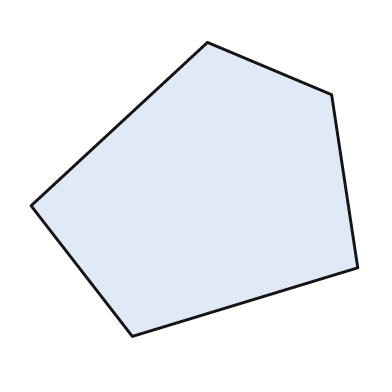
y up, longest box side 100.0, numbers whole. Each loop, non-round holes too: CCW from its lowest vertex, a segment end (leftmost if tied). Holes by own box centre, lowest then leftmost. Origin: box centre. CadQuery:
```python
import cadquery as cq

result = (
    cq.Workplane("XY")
    .moveTo(-19.0, -45.0)
    .lineTo(50.0, -24.0)
    .lineTo(42.0, 29.0)
    .lineTo(4.0, 45.0)
    .lineTo(-50.0, -5.0)
    .close()
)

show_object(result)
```